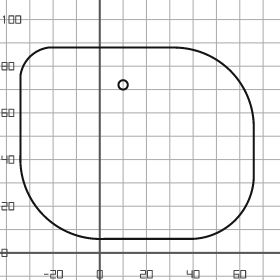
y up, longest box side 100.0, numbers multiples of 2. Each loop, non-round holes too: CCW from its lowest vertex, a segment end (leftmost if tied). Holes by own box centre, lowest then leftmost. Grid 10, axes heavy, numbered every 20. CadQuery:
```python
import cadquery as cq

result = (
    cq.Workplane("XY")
    .moveTo(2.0, 6.0)
    .lineTo(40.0, 6.0)
    .threePointArc((58.0, 14.0), (66.0, 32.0))
    .lineTo(66.0, 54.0)
    .threePointArc((56.0, 78.0), (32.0, 88.0))
    .lineTo(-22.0, 88.0)
    .threePointArc((-30.0, 84.0), (-34.0, 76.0))
    .lineTo(-34.0, 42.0)
    .threePointArc((-24.0, 16.0), (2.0, 6.0))
    .close()
    .moveTo(10.0, 72.0)
    .circle(2.0)
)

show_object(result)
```